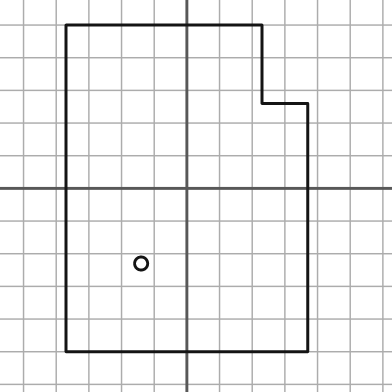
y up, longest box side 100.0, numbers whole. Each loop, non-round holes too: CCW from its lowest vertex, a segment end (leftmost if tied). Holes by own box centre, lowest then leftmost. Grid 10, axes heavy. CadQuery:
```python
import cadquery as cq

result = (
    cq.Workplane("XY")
    .moveTo(-37.0, -50.0)
    .lineTo(37.0, -50.0)
    .lineTo(37.0, 26.0)
    .lineTo(23.0, 26.0)
    .lineTo(23.0, 50.0)
    .lineTo(-37.0, 50.0)
    .close()
    .moveTo(-14.0, -23.0)
    .circle(2.0)
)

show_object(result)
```